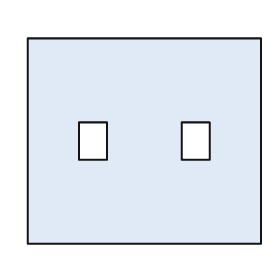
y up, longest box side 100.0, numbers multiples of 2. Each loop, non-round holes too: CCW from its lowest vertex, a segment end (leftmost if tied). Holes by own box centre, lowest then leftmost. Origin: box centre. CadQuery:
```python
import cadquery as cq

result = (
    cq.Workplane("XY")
    .moveTo(-50.0, -44.0)
    .lineTo(50.0, -44.0)
    .lineTo(50.0, 44.0)
    .lineTo(-50.0, 44.0)
    .close()
    .moveTo(-28.0, -8.0)
    .lineTo(-16.0, -8.0)
    .lineTo(-16.0, 8.0)
    .lineTo(-28.0, 8.0)
    .close()
    .moveTo(16.0, -8.0)
    .lineTo(28.0, -8.0)
    .lineTo(28.0, 8.0)
    .lineTo(16.0, 8.0)
    .close()
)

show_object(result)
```